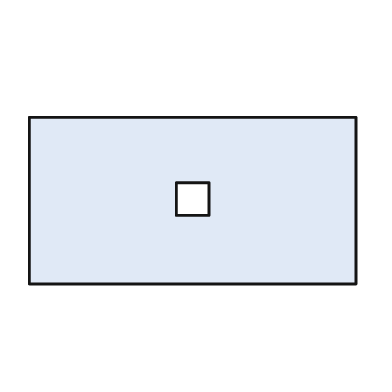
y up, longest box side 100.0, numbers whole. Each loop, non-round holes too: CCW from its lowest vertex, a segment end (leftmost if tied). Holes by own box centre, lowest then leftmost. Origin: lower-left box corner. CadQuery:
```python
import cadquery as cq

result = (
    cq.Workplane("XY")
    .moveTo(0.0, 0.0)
    .lineTo(100.0, 0.0)
    .lineTo(100.0, 51.0)
    .lineTo(0.0, 51.0)
    .close()
    .moveTo(45.0, 21.0)
    .lineTo(55.0, 21.0)
    .lineTo(55.0, 31.0)
    .lineTo(45.0, 31.0)
    .close()
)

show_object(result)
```